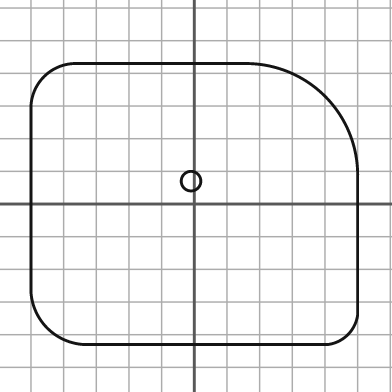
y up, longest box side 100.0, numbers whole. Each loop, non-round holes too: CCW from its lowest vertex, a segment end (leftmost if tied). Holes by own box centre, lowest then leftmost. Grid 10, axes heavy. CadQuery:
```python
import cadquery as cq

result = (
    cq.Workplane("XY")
    .moveTo(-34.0, -43.0)
    .lineTo(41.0, -43.0)
    .threePointArc((47.0, -40.0), (50.0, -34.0))
    .lineTo(50.0, 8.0)
    .threePointArc((40.0, 33.0), (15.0, 43.0))
    .lineTo(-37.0, 43.0)
    .threePointArc((-46.0, 39.0), (-50.0, 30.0))
    .lineTo(-50.0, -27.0)
    .threePointArc((-45.0, -38.0), (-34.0, -43.0))
    .close()
    .moveTo(-1.0, 7.0)
    .circle(3.0)
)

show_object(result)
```